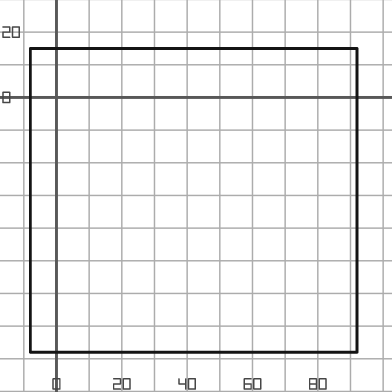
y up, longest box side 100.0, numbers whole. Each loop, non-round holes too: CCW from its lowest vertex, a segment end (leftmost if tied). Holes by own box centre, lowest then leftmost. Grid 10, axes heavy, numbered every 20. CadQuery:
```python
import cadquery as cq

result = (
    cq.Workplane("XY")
    .moveTo(-8.0, -78.0)
    .lineTo(92.0, -78.0)
    .lineTo(92.0, 15.0)
    .lineTo(-8.0, 15.0)
    .close()
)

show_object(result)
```